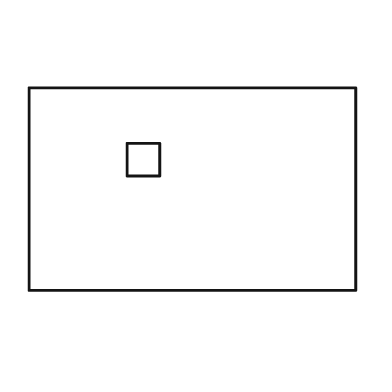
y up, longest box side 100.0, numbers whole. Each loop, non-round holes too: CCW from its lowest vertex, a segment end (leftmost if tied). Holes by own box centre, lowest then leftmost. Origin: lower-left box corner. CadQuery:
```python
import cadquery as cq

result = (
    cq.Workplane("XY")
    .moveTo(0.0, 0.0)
    .lineTo(100.0, 0.0)
    .lineTo(100.0, 62.0)
    .lineTo(0.0, 62.0)
    .close()
    .moveTo(30.0, 35.0)
    .lineTo(40.0, 35.0)
    .lineTo(40.0, 45.0)
    .lineTo(30.0, 45.0)
    .close()
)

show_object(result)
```